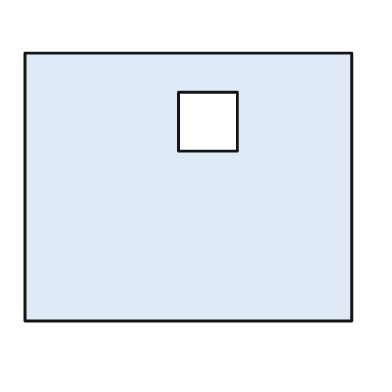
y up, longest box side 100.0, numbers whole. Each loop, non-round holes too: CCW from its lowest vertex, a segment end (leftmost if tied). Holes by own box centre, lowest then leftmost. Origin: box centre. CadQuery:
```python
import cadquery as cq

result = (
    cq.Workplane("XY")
    .moveTo(-50.0, -41.0)
    .lineTo(50.0, -41.0)
    .lineTo(50.0, 41.0)
    .lineTo(-50.0, 41.0)
    .close()
    .moveTo(-3.0, 11.0)
    .lineTo(15.0, 11.0)
    .lineTo(15.0, 29.0)
    .lineTo(-3.0, 29.0)
    .close()
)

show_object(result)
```